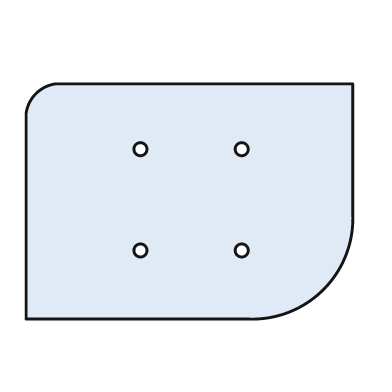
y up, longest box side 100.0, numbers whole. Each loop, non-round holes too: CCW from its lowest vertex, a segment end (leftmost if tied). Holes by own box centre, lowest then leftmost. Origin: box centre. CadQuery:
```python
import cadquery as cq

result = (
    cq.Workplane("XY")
    .moveTo(-50.0, -36.0)
    .lineTo(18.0, -36.0)
    .threePointArc((41.0, -27.0), (50.0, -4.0))
    .lineTo(50.0, 36.0)
    .lineTo(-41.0, 36.0)
    .threePointArc((-47.0, 33.0), (-50.0, 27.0))
    .close()
    .moveTo(-15.0, -15.0)
    .circle(2.0)
    .moveTo(16.0, -15.0)
    .circle(2.0)
    .moveTo(-15.0, 16.0)
    .circle(2.0)
    .moveTo(16.0, 16.0)
    .circle(2.0)
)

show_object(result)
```